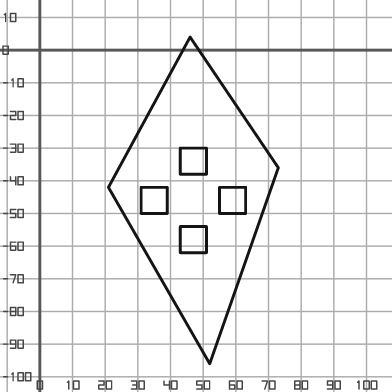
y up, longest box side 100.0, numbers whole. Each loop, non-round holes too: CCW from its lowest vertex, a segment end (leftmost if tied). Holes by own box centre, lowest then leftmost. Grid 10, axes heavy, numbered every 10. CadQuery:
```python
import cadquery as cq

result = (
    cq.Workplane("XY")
    .moveTo(52.0, -96.0)
    .lineTo(73.0, -36.0)
    .lineTo(46.0, 4.0)
    .lineTo(21.0, -42.0)
    .close()
    .moveTo(43.0, -62.0)
    .lineTo(51.0, -62.0)
    .lineTo(51.0, -54.0)
    .lineTo(43.0, -54.0)
    .close()
    .moveTo(31.0, -50.0)
    .lineTo(39.0, -50.0)
    .lineTo(39.0, -42.0)
    .lineTo(31.0, -42.0)
    .close()
    .moveTo(55.0, -50.0)
    .lineTo(63.0, -50.0)
    .lineTo(63.0, -42.0)
    .lineTo(55.0, -42.0)
    .close()
    .moveTo(43.0, -38.0)
    .lineTo(51.0, -38.0)
    .lineTo(51.0, -30.0)
    .lineTo(43.0, -30.0)
    .close()
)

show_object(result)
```